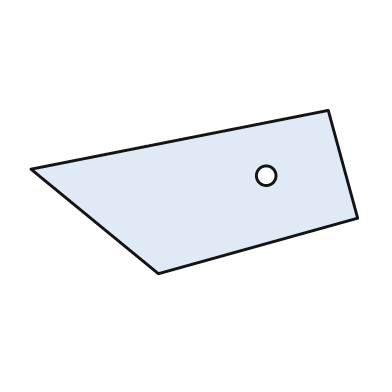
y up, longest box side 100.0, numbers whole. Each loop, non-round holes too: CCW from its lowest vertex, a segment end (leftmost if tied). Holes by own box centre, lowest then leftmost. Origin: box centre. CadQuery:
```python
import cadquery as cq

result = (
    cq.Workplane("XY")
    .moveTo(-11.0, -25.0)
    .lineTo(50.0, -8.0)
    .lineTo(41.0, 25.0)
    .lineTo(-50.0, 7.0)
    .close()
    .moveTo(22.0, 5.0)
    .circle(3.0)
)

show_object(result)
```